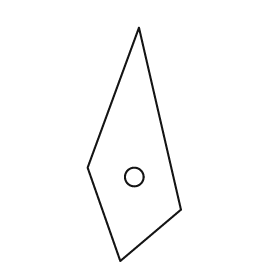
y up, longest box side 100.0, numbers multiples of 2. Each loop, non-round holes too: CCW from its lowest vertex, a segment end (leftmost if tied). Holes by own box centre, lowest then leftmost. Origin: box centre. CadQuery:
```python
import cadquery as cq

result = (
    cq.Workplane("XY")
    .moveTo(-6.0, -50.0)
    .lineTo(20.0, -28.0)
    .lineTo(2.0, 50.0)
    .lineTo(-20.0, -10.0)
    .close()
    .moveTo(0.0, -14.0)
    .circle(4.0)
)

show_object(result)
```